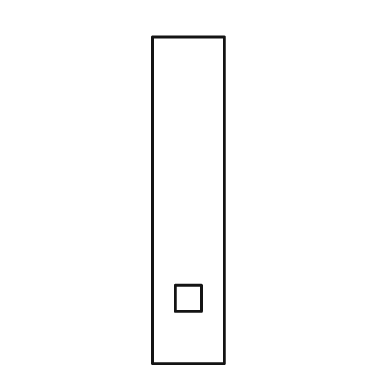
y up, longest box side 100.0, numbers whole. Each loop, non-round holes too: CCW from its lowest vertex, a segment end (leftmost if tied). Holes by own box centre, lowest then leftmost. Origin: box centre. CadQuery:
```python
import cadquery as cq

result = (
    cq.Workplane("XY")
    .moveTo(-11.0, -50.0)
    .lineTo(11.0, -50.0)
    .lineTo(11.0, 50.0)
    .lineTo(-11.0, 50.0)
    .close()
    .moveTo(-4.0, -34.0)
    .lineTo(4.0, -34.0)
    .lineTo(4.0, -26.0)
    .lineTo(-4.0, -26.0)
    .close()
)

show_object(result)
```